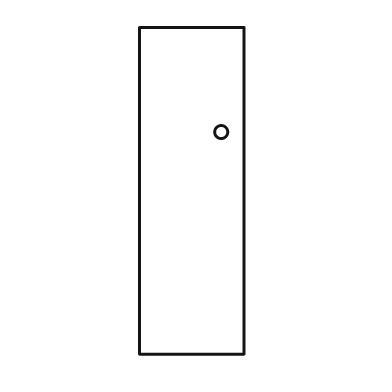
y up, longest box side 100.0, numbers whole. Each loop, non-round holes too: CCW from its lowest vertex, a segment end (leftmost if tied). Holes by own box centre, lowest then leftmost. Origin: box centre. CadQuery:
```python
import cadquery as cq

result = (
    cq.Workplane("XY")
    .moveTo(-16.0, -50.0)
    .lineTo(16.0, -50.0)
    .lineTo(16.0, 50.0)
    .lineTo(-16.0, 50.0)
    .close()
    .moveTo(9.0, 18.0)
    .circle(2.0)
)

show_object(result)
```